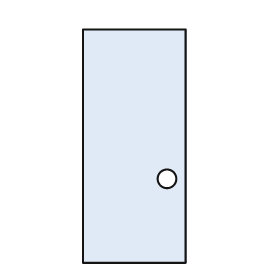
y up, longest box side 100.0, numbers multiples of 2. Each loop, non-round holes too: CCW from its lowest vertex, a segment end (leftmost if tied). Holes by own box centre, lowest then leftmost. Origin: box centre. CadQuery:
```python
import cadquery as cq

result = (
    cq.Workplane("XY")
    .moveTo(-22.0, -50.0)
    .lineTo(22.0, -50.0)
    .lineTo(22.0, 50.0)
    .lineTo(-22.0, 50.0)
    .close()
    .moveTo(14.0, -14.0)
    .circle(4.0)
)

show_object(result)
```